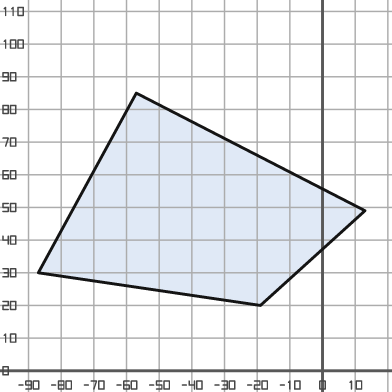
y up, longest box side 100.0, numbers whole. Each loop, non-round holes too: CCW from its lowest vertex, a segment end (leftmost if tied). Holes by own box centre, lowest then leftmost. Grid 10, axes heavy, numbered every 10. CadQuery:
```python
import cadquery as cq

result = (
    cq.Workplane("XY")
    .moveTo(-19.0, 20.0)
    .lineTo(13.0, 49.0)
    .lineTo(-57.0, 85.0)
    .lineTo(-87.0, 30.0)
    .close()
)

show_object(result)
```